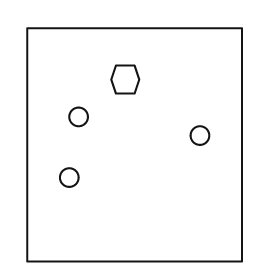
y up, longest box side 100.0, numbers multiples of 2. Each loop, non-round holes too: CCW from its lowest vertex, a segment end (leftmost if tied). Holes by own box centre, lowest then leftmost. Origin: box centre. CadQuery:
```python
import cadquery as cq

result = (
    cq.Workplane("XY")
    .moveTo(-46.0, -50.0)
    .lineTo(46.0, -50.0)
    .lineTo(46.0, 50.0)
    .lineTo(-46.0, 50.0)
    .close()
    .moveTo(-28.0, -14.0)
    .circle(4.0)
    .moveTo(28.0, 4.0)
    .circle(4.0)
    .moveTo(-24.0, 12.0)
    .circle(4.0)
    .moveTo(-8.0, 22.0)
    .lineTo(0.0, 22.0)
    .lineTo(2.0, 28.0)
    .lineTo(0.0, 34.0)
    .lineTo(-8.0, 34.0)
    .lineTo(-10.0, 28.0)
    .close()
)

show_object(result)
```